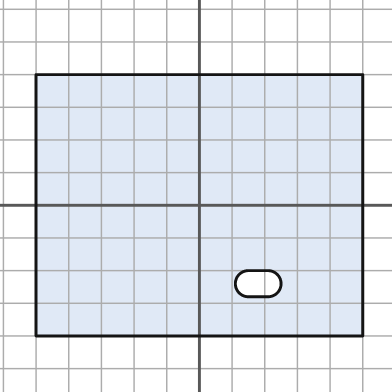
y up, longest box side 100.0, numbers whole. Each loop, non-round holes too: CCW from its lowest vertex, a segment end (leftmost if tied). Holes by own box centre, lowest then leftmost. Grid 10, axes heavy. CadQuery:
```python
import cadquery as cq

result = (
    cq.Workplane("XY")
    .moveTo(-50.0, -40.0)
    .lineTo(50.0, -40.0)
    .lineTo(50.0, 40.0)
    .lineTo(-50.0, 40.0)
    .close()
    .moveTo(15.0, -28.0)
    .lineTo(21.0, -28.0)
    .threePointArc((25.0, -24.0), (21.0, -20.0))
    .lineTo(15.0, -20.0)
    .threePointArc((11.0, -24.0), (15.0, -28.0))
    .close()
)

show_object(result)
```